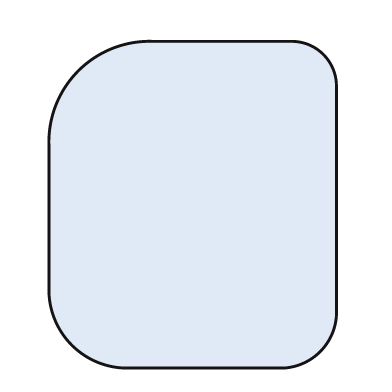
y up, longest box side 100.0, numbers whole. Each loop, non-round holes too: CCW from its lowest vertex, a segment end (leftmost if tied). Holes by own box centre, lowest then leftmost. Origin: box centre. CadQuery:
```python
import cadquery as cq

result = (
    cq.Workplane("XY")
    .moveTo(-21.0, -50.0)
    .lineTo(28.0, -50.0)
    .threePointArc((39.0, -45.0), (44.0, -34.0))
    .lineTo(44.0, 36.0)
    .threePointArc((40.0, 46.0), (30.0, 50.0))
    .lineTo(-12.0, 50.0)
    .threePointArc((-35.0, 41.0), (-44.0, 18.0))
    .lineTo(-44.0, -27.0)
    .threePointArc((-37.0, -43.0), (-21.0, -50.0))
    .close()
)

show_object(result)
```